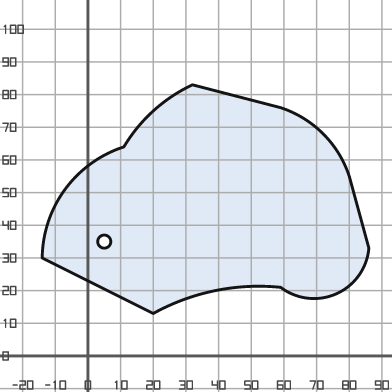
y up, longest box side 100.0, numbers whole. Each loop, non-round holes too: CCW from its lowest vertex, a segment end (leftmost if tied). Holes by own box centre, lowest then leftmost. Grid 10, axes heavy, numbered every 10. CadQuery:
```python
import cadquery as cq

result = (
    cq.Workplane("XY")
    .moveTo(20.0, 13.0)
    .threePointArc((39.0, 20.0), (59.0, 21.0))
    .threePointArc((76.0, 19.0), (86.0, 33.0))
    .lineTo(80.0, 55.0)
    .threePointArc((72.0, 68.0), (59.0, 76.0))
    .lineTo(32.0, 83.0)
    .threePointArc((20.0, 75.0), (11.0, 64.0))
    .threePointArc((-7.0, 51.0), (-14.0, 30.0))
    .close()
    .moveTo(5.0, 35.0)
    .circle(2.0)
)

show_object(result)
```